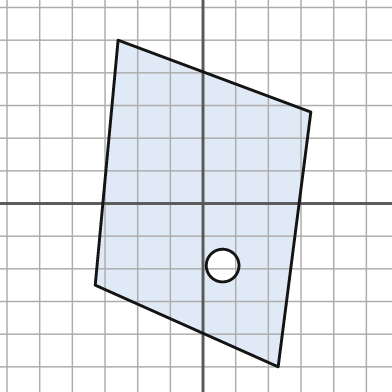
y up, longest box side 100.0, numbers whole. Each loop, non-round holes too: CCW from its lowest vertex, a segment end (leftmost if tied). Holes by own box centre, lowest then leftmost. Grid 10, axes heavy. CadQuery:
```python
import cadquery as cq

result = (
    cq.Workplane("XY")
    .moveTo(23.0, -50.0)
    .lineTo(33.0, 28.0)
    .lineTo(-26.0, 50.0)
    .lineTo(-33.0, -25.0)
    .close()
    .moveTo(6.0, -19.0)
    .circle(5.0)
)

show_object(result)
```